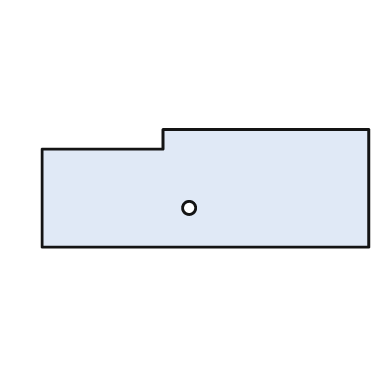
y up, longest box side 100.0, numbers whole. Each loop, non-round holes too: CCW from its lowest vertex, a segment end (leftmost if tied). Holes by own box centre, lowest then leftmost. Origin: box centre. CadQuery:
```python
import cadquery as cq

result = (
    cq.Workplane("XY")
    .moveTo(-50.0, -18.0)
    .lineTo(50.0, -18.0)
    .lineTo(50.0, 18.0)
    .lineTo(-13.0, 18.0)
    .lineTo(-13.0, 12.0)
    .lineTo(-50.0, 12.0)
    .close()
    .moveTo(-5.0, -6.0)
    .circle(2.0)
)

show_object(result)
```